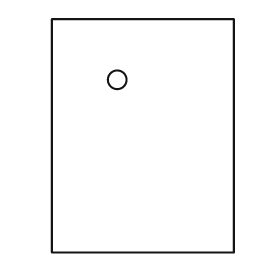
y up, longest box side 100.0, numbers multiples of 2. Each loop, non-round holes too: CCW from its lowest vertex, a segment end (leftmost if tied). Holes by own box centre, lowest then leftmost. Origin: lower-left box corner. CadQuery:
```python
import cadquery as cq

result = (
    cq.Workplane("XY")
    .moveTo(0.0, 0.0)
    .lineTo(78.0, 0.0)
    .lineTo(78.0, 100.0)
    .lineTo(0.0, 100.0)
    .close()
    .moveTo(28.0, 74.0)
    .circle(4.0)
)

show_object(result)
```